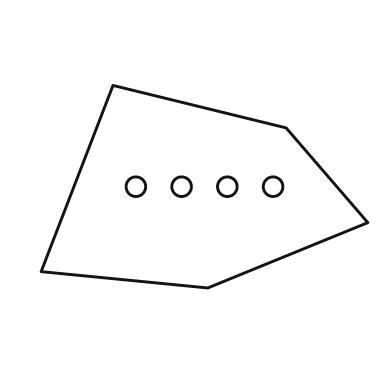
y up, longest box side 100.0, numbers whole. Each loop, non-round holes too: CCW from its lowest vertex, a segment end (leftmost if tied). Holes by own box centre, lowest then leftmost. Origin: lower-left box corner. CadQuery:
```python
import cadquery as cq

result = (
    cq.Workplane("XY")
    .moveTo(51.0, 0.0)
    .lineTo(100.0, 20.0)
    .lineTo(75.0, 49.0)
    .lineTo(22.0, 62.0)
    .lineTo(0.0, 5.0)
    .close()
    .moveTo(29.0, 31.0)
    .circle(3.0)
    .moveTo(43.0, 31.0)
    .circle(3.0)
    .moveTo(57.0, 31.0)
    .circle(3.0)
    .moveTo(71.0, 31.0)
    .circle(3.0)
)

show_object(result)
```